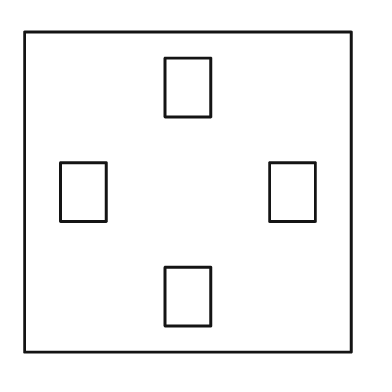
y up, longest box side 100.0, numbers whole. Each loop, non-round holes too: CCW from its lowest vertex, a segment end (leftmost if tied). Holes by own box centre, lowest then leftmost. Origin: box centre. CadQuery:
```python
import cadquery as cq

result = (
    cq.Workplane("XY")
    .moveTo(-50.0, -49.0)
    .lineTo(50.0, -49.0)
    .lineTo(50.0, 49.0)
    .lineTo(-50.0, 49.0)
    .close()
    .moveTo(-7.0, -41.0)
    .lineTo(7.0, -41.0)
    .lineTo(7.0, -23.0)
    .lineTo(-7.0, -23.0)
    .close()
    .moveTo(-39.0, -9.0)
    .lineTo(-25.0, -9.0)
    .lineTo(-25.0, 9.0)
    .lineTo(-39.0, 9.0)
    .close()
    .moveTo(25.0, -9.0)
    .lineTo(39.0, -9.0)
    .lineTo(39.0, 9.0)
    .lineTo(25.0, 9.0)
    .close()
    .moveTo(-7.0, 23.0)
    .lineTo(7.0, 23.0)
    .lineTo(7.0, 41.0)
    .lineTo(-7.0, 41.0)
    .close()
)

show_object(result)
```